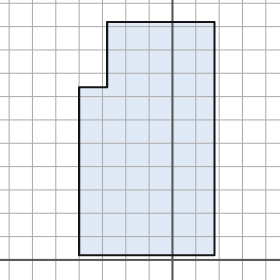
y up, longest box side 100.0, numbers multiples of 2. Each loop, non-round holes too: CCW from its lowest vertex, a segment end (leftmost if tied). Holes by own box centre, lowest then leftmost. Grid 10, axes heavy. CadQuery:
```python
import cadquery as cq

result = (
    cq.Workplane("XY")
    .moveTo(-40.0, 2.0)
    .lineTo(18.0, 2.0)
    .lineTo(18.0, 102.0)
    .lineTo(-28.0, 102.0)
    .lineTo(-28.0, 74.0)
    .lineTo(-40.0, 74.0)
    .close()
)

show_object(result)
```